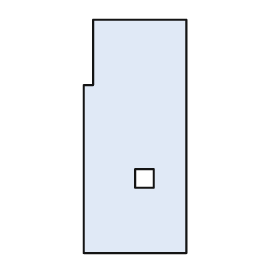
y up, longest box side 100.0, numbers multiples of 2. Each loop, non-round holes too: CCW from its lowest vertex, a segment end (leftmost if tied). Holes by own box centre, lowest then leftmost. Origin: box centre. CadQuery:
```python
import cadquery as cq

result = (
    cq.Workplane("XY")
    .moveTo(-22.0, -50.0)
    .lineTo(22.0, -50.0)
    .lineTo(22.0, 50.0)
    .lineTo(-18.0, 50.0)
    .lineTo(-18.0, 22.0)
    .lineTo(-22.0, 22.0)
    .close()
    .moveTo(0.0, -22.0)
    .lineTo(8.0, -22.0)
    .lineTo(8.0, -14.0)
    .lineTo(0.0, -14.0)
    .close()
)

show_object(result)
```